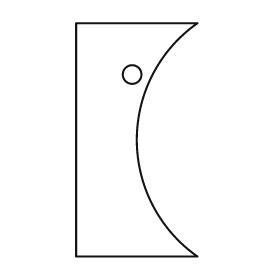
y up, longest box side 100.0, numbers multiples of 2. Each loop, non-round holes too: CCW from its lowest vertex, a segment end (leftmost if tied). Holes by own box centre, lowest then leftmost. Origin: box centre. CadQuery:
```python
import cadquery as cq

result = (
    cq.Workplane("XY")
    .moveTo(-26.0, -50.0)
    .lineTo(26.0, -50.0)
    .threePointArc((0.0, 0.0), (26.0, 50.0))
    .lineTo(-26.0, 50.0)
    .close()
    .moveTo(-2.0, 28.0)
    .circle(4.0)
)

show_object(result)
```